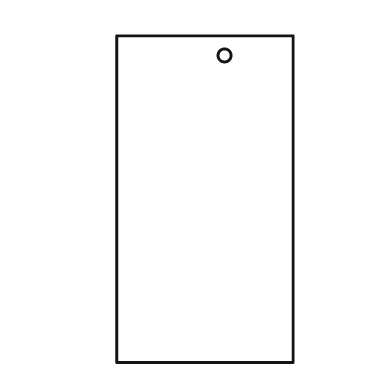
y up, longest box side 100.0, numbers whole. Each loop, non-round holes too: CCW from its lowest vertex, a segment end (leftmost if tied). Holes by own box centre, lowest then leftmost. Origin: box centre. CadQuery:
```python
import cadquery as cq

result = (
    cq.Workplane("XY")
    .moveTo(-27.0, -50.0)
    .lineTo(27.0, -50.0)
    .lineTo(27.0, 50.0)
    .lineTo(-27.0, 50.0)
    .close()
    .moveTo(6.0, 44.0)
    .circle(2.0)
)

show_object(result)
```